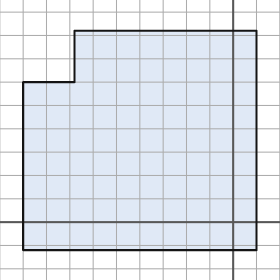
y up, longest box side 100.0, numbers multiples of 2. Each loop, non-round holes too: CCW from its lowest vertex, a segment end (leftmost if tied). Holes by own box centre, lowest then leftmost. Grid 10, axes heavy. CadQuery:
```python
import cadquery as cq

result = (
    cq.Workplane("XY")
    .moveTo(-90.0, -12.0)
    .lineTo(10.0, -12.0)
    .lineTo(10.0, 82.0)
    .lineTo(-68.0, 82.0)
    .lineTo(-68.0, 60.0)
    .lineTo(-90.0, 60.0)
    .close()
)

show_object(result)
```